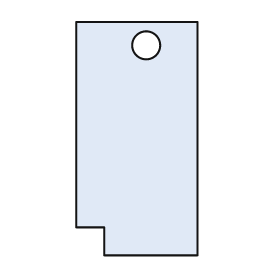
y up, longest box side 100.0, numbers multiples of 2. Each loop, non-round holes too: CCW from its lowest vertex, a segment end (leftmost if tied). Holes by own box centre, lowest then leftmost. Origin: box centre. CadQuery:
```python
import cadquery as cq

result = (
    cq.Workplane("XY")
    .moveTo(-14.0, -50.0)
    .lineTo(26.0, -50.0)
    .lineTo(26.0, 50.0)
    .lineTo(-26.0, 50.0)
    .lineTo(-26.0, -38.0)
    .lineTo(-14.0, -38.0)
    .close()
    .moveTo(4.0, 40.0)
    .circle(6.0)
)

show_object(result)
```